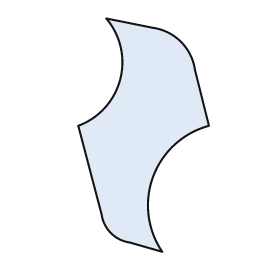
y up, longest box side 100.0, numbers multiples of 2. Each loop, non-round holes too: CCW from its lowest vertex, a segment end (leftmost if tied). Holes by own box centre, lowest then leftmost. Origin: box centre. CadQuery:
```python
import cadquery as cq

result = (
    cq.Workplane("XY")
    .moveTo(8.0, -50.0)
    .threePointArc((4.0, -18.0), (28.0, 4.0))
    .lineTo(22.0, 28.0)
    .threePointArc((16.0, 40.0), (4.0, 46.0))
    .lineTo(-16.0, 50.0)
    .threePointArc((-10.0, 24.0), (-28.0, 4.0))
    .lineTo(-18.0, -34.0)
    .threePointArc((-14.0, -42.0), (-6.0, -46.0))
    .close()
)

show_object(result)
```